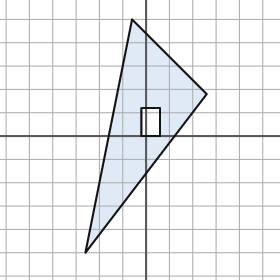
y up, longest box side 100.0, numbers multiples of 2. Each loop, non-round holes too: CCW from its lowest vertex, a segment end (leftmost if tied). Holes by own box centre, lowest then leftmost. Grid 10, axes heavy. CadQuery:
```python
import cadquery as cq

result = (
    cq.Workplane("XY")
    .moveTo(-26.0, -50.0)
    .lineTo(26.0, 18.0)
    .lineTo(-6.0, 50.0)
    .close()
    .moveTo(-2.0, 0.0)
    .lineTo(6.0, 0.0)
    .lineTo(6.0, 12.0)
    .lineTo(-2.0, 12.0)
    .close()
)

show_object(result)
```